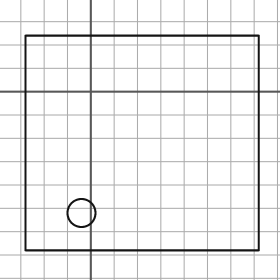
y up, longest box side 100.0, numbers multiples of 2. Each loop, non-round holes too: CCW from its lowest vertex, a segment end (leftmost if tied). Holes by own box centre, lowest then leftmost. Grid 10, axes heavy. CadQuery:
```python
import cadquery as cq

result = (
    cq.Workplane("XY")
    .moveTo(-28.0, -68.0)
    .lineTo(72.0, -68.0)
    .lineTo(72.0, 24.0)
    .lineTo(-28.0, 24.0)
    .close()
    .moveTo(-4.0, -52.0)
    .circle(6.0)
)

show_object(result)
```